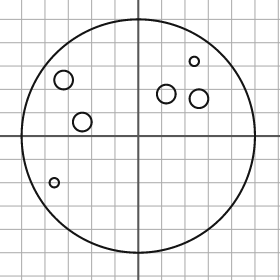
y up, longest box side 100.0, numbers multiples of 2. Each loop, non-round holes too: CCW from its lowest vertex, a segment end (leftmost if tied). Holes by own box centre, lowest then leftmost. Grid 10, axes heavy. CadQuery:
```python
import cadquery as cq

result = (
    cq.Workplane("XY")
    .moveTo(0.0, 0.0)
    .circle(50.0)
    .moveTo(-36.0, -20.0)
    .circle(2.0)
    .moveTo(-24.0, 6.0)
    .circle(4.0)
    .moveTo(26.0, 16.0)
    .circle(4.0)
    .moveTo(12.0, 18.0)
    .circle(4.0)
    .moveTo(-32.0, 24.0)
    .circle(4.0)
    .moveTo(24.0, 32.0)
    .circle(2.0)
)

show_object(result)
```